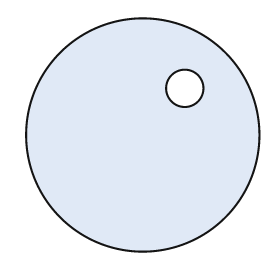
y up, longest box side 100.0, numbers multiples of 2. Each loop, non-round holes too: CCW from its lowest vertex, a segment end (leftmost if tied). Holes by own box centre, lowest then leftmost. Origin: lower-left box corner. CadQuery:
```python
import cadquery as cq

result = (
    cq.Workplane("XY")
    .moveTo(50.0, 50.0)
    .circle(50.0)
    .moveTo(68.0, 70.0)
    .circle(8.0)
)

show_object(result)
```